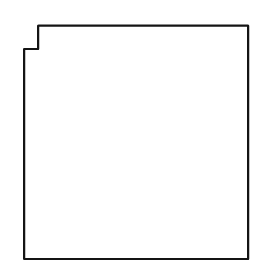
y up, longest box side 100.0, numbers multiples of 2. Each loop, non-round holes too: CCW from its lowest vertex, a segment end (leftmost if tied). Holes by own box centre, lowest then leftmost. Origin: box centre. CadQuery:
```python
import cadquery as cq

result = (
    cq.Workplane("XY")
    .moveTo(-48.0, -50.0)
    .lineTo(48.0, -50.0)
    .lineTo(48.0, 50.0)
    .lineTo(-42.0, 50.0)
    .lineTo(-42.0, 40.0)
    .lineTo(-48.0, 40.0)
    .close()
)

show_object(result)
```